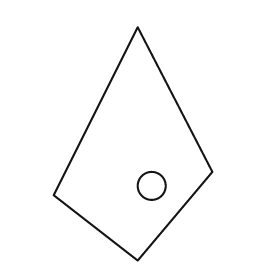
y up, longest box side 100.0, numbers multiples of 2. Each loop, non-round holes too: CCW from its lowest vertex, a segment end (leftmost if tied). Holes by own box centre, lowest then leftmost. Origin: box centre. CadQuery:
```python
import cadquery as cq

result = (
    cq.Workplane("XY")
    .moveTo(2.0, -50.0)
    .lineTo(34.0, -12.0)
    .lineTo(2.0, 50.0)
    .lineTo(-34.0, -22.0)
    .close()
    .moveTo(8.0, -18.0)
    .circle(6.0)
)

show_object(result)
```